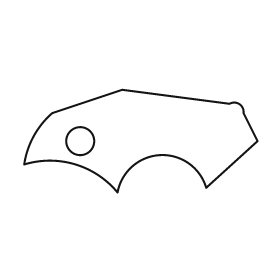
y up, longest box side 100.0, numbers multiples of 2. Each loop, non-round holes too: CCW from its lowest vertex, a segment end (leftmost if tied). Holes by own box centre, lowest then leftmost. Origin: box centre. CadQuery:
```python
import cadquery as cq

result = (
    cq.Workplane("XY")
    .moveTo(-10.0, -22.0)
    .threePointArc((8.0, -6.0), (28.0, -20.0))
    .lineTo(50.0, 0.0)
    .lineTo(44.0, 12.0)
    .threePointArc((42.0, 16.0), (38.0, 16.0))
    .lineTo(-8.0, 22.0)
    .lineTo(-38.0, 12.0)
    .threePointArc((-46.0, 2.0), (-50.0, -10.0))
    .threePointArc((-28.0, -10.0), (-10.0, -22.0))
    .close()
    .moveTo(-26.0, 0.0)
    .circle(6.0)
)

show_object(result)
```